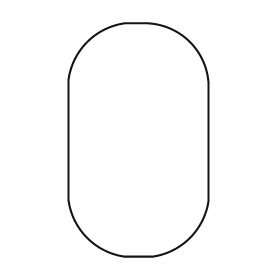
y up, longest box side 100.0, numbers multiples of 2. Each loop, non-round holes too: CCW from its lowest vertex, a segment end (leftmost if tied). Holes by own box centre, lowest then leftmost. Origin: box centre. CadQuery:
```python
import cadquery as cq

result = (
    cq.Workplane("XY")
    .moveTo(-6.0, -50.0)
    .lineTo(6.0, -50.0)
    .threePointArc((22.0, -42.0), (30.0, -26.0))
    .lineTo(30.0, 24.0)
    .threePointArc((22.0, 42.0), (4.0, 50.0))
    .lineTo(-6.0, 50.0)
    .threePointArc((-22.0, 42.0), (-30.0, 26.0))
    .lineTo(-30.0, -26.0)
    .threePointArc((-22.0, -42.0), (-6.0, -50.0))
    .close()
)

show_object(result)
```